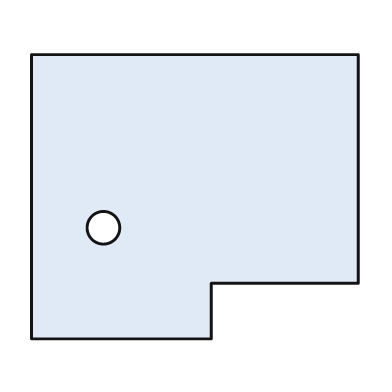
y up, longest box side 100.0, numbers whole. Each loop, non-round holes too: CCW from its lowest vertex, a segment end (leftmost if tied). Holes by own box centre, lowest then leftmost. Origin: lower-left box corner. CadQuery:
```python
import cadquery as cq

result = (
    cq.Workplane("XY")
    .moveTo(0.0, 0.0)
    .lineTo(55.0, 0.0)
    .lineTo(55.0, 17.0)
    .lineTo(100.0, 17.0)
    .lineTo(100.0, 87.0)
    .lineTo(0.0, 87.0)
    .close()
    .moveTo(22.0, 34.0)
    .circle(5.0)
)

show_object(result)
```